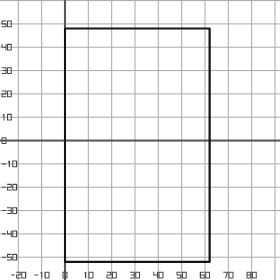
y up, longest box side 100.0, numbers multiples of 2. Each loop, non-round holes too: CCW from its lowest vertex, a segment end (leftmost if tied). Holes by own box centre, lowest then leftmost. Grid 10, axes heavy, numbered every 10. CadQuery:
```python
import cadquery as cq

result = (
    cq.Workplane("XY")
    .moveTo(0.0, -52.0)
    .lineTo(62.0, -52.0)
    .lineTo(62.0, 48.0)
    .lineTo(0.0, 48.0)
    .close()
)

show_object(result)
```